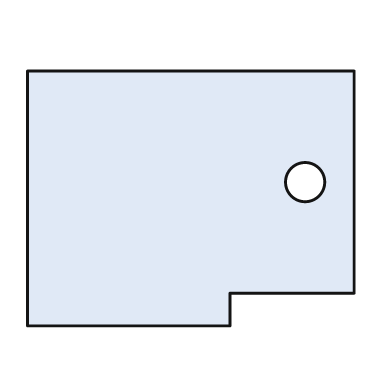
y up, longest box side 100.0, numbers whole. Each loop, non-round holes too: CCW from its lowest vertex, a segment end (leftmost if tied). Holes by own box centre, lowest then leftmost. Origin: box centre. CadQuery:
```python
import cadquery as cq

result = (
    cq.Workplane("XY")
    .moveTo(-50.0, -39.0)
    .lineTo(12.0, -39.0)
    .lineTo(12.0, -29.0)
    .lineTo(50.0, -29.0)
    .lineTo(50.0, 39.0)
    .lineTo(-50.0, 39.0)
    .close()
    .moveTo(35.0, 5.0)
    .circle(6.0)
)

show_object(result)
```